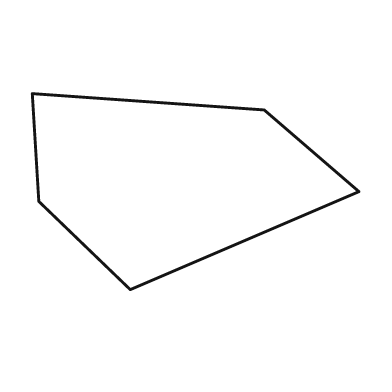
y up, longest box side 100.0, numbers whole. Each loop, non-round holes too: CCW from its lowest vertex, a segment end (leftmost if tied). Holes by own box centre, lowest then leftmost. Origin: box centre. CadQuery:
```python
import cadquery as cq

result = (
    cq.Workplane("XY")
    .moveTo(-20.0, -30.0)
    .lineTo(50.0, 0.0)
    .lineTo(21.0, 25.0)
    .lineTo(-50.0, 30.0)
    .lineTo(-48.0, -3.0)
    .close()
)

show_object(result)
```